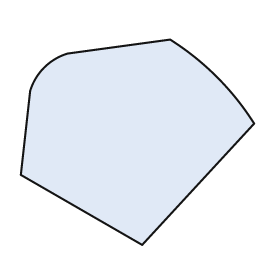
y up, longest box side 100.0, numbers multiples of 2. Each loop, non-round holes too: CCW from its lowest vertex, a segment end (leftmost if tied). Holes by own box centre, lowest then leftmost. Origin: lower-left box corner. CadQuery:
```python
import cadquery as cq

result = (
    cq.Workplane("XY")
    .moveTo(52.0, 0.0)
    .lineTo(100.0, 52.0)
    .threePointArc((84.0, 72.0), (64.0, 88.0))
    .lineTo(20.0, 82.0)
    .threePointArc((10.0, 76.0), (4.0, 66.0))
    .lineTo(0.0, 30.0)
    .close()
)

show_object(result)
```